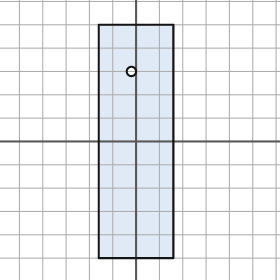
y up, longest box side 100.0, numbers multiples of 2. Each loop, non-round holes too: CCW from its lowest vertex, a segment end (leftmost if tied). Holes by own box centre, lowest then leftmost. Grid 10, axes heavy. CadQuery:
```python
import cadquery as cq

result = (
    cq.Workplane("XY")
    .moveTo(-16.0, -50.0)
    .lineTo(16.0, -50.0)
    .lineTo(16.0, 50.0)
    .lineTo(-16.0, 50.0)
    .close()
    .moveTo(-2.0, 30.0)
    .circle(2.0)
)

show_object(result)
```